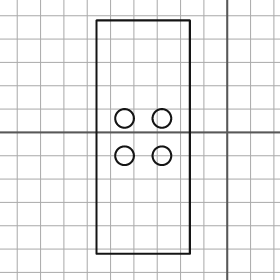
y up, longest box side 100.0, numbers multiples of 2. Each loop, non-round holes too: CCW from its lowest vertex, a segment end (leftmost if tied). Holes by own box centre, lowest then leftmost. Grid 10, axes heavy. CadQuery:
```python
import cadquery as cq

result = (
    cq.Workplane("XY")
    .moveTo(-56.0, -52.0)
    .lineTo(-16.0, -52.0)
    .lineTo(-16.0, 48.0)
    .lineTo(-56.0, 48.0)
    .close()
    .moveTo(-44.0, -10.0)
    .circle(4.0)
    .moveTo(-28.0, -10.0)
    .circle(4.0)
    .moveTo(-44.0, 6.0)
    .circle(4.0)
    .moveTo(-28.0, 6.0)
    .circle(4.0)
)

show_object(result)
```